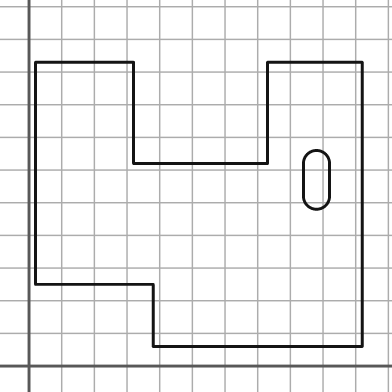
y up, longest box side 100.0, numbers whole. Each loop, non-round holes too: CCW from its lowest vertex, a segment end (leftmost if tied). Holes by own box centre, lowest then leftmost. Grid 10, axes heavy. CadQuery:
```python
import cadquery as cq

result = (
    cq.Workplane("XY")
    .moveTo(38.0, 6.0)
    .lineTo(102.0, 6.0)
    .lineTo(102.0, 93.0)
    .lineTo(73.0, 93.0)
    .lineTo(73.0, 62.0)
    .lineTo(32.0, 62.0)
    .lineTo(32.0, 93.0)
    .lineTo(2.0, 93.0)
    .lineTo(2.0, 25.0)
    .lineTo(38.0, 25.0)
    .close()
    .moveTo(84.0, 52.0)
    .threePointArc((88.0, 48.0), (92.0, 52.0))
    .lineTo(92.0, 62.0)
    .threePointArc((88.0, 66.0), (84.0, 62.0))
    .close()
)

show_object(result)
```